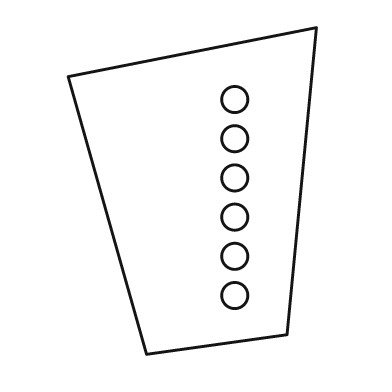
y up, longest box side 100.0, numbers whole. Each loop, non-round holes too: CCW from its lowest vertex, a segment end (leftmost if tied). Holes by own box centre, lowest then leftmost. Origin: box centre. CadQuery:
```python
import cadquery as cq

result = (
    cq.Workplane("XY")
    .moveTo(-14.0, -50.0)
    .lineTo(29.0, -44.0)
    .lineTo(38.0, 50.0)
    .lineTo(-38.0, 35.0)
    .close()
    .moveTo(13.0, -32.0)
    .circle(4.0)
    .moveTo(13.0, -20.0)
    .circle(4.0)
    .moveTo(13.0, -8.0)
    .circle(4.0)
    .moveTo(13.0, 4.0)
    .circle(4.0)
    .moveTo(13.0, 16.0)
    .circle(4.0)
    .moveTo(13.0, 28.0)
    .circle(4.0)
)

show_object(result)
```